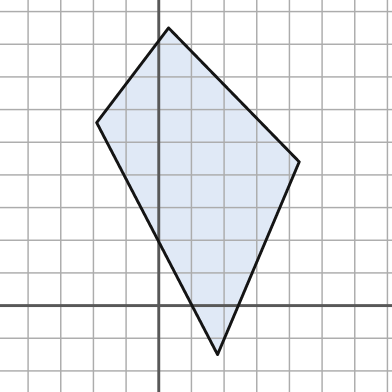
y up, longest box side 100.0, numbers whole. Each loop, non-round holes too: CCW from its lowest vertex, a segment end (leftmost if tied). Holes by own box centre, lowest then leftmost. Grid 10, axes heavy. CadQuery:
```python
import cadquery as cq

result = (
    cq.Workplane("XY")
    .moveTo(18.0, -15.0)
    .lineTo(43.0, 44.0)
    .lineTo(3.0, 85.0)
    .lineTo(-19.0, 56.0)
    .close()
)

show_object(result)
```